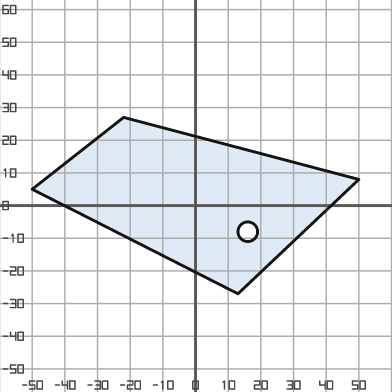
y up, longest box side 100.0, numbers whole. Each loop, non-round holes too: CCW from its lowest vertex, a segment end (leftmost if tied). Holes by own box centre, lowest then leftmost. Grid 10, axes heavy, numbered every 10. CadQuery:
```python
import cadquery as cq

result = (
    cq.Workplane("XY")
    .moveTo(13.0, -27.0)
    .lineTo(50.0, 8.0)
    .lineTo(-22.0, 27.0)
    .lineTo(-50.0, 5.0)
    .close()
    .moveTo(16.0, -8.0)
    .circle(3.0)
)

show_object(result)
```